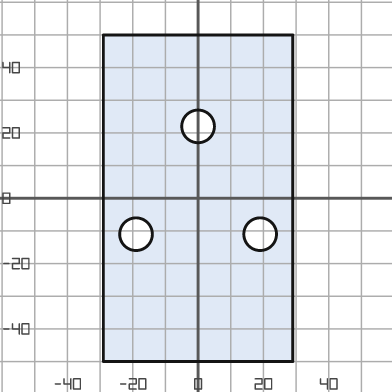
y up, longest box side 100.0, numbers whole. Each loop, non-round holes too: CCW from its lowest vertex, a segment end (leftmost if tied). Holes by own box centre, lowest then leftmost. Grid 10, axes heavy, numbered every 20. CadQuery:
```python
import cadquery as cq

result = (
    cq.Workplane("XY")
    .moveTo(-29.0, -50.0)
    .lineTo(29.0, -50.0)
    .lineTo(29.0, 50.0)
    .lineTo(-29.0, 50.0)
    .close()
    .moveTo(-19.0, -11.0)
    .circle(5.0)
    .moveTo(19.0, -11.0)
    .circle(5.0)
    .moveTo(0.0, 22.0)
    .circle(5.0)
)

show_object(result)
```